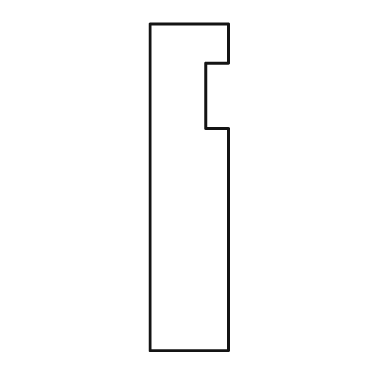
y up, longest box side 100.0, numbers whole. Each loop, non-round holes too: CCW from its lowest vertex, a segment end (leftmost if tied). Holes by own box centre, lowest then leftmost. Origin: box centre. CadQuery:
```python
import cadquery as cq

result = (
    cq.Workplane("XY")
    .moveTo(-12.0, -50.0)
    .lineTo(12.0, -50.0)
    .lineTo(12.0, 18.0)
    .lineTo(5.0, 18.0)
    .lineTo(5.0, 38.0)
    .lineTo(12.0, 38.0)
    .lineTo(12.0, 50.0)
    .lineTo(-12.0, 50.0)
    .close()
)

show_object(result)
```